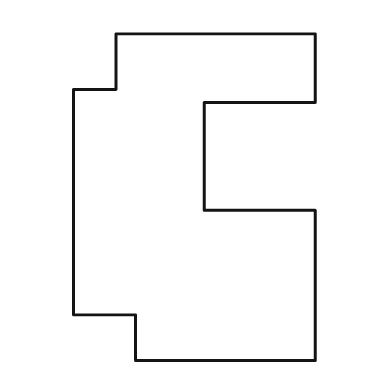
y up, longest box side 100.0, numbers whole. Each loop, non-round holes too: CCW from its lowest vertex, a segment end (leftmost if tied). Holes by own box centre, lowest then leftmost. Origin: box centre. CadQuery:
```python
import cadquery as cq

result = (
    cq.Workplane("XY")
    .moveTo(-18.0, -50.0)
    .lineTo(37.0, -50.0)
    .lineTo(37.0, -4.0)
    .lineTo(3.0, -4.0)
    .lineTo(3.0, 29.0)
    .lineTo(37.0, 29.0)
    .lineTo(37.0, 50.0)
    .lineTo(-24.0, 50.0)
    .lineTo(-24.0, 33.0)
    .lineTo(-37.0, 33.0)
    .lineTo(-37.0, -36.0)
    .lineTo(-18.0, -36.0)
    .close()
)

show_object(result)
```